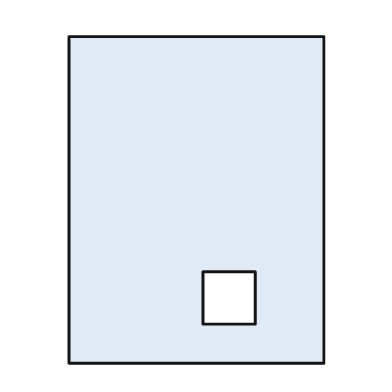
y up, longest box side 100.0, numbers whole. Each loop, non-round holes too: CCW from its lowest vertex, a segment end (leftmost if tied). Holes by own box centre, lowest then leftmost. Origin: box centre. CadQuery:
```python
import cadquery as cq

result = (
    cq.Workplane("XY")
    .moveTo(-39.0, -50.0)
    .lineTo(39.0, -50.0)
    .lineTo(39.0, 50.0)
    .lineTo(-39.0, 50.0)
    .close()
    .moveTo(2.0, -38.0)
    .lineTo(18.0, -38.0)
    .lineTo(18.0, -22.0)
    .lineTo(2.0, -22.0)
    .close()
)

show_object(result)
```